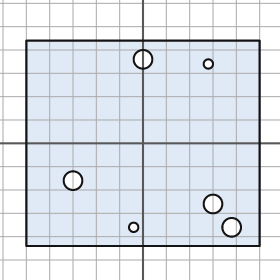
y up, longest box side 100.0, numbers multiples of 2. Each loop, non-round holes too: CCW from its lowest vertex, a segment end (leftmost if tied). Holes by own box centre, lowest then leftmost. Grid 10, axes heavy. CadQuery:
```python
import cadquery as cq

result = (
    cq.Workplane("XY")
    .moveTo(-50.0, -44.0)
    .lineTo(50.0, -44.0)
    .lineTo(50.0, 44.0)
    .lineTo(-50.0, 44.0)
    .close()
    .moveTo(-4.0, -36.0)
    .circle(2.0)
    .moveTo(38.0, -36.0)
    .circle(4.0)
    .moveTo(30.0, -26.0)
    .circle(4.0)
    .moveTo(-30.0, -16.0)
    .circle(4.0)
    .moveTo(28.0, 34.0)
    .circle(2.0)
    .moveTo(0.0, 36.0)
    .circle(4.0)
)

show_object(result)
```